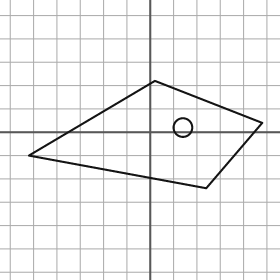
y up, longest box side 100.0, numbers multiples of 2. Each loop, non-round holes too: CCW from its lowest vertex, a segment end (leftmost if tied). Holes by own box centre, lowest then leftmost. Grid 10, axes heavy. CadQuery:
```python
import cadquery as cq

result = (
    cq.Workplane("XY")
    .moveTo(24.0, -24.0)
    .lineTo(48.0, 4.0)
    .lineTo(2.0, 22.0)
    .lineTo(-52.0, -10.0)
    .close()
    .moveTo(14.0, 2.0)
    .circle(4.0)
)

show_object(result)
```